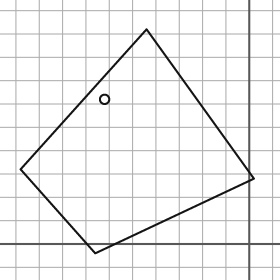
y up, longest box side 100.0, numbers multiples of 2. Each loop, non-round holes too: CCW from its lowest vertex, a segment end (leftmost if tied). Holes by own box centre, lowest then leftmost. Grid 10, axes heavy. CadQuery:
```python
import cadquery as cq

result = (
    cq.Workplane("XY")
    .moveTo(-66.0, -4.0)
    .lineTo(2.0, 28.0)
    .lineTo(-44.0, 92.0)
    .lineTo(-98.0, 32.0)
    .close()
    .moveTo(-62.0, 62.0)
    .circle(2.0)
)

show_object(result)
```